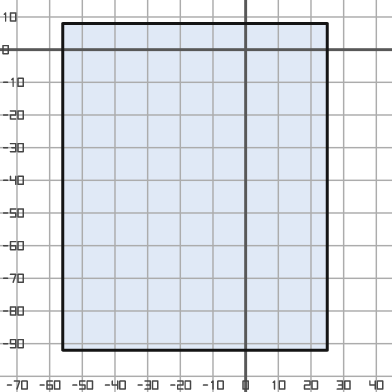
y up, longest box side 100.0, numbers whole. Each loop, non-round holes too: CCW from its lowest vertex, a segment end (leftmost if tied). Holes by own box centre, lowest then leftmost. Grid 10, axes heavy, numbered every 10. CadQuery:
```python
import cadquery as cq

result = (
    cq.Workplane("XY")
    .moveTo(-56.0, -92.0)
    .lineTo(25.0, -92.0)
    .lineTo(25.0, 8.0)
    .lineTo(-56.0, 8.0)
    .close()
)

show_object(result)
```